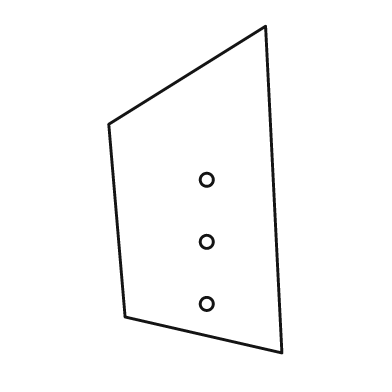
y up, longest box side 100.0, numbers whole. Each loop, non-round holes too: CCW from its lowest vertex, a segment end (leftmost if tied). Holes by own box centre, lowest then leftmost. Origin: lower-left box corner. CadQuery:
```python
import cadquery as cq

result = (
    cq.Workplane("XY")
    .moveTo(53.0, 0.0)
    .lineTo(48.0, 100.0)
    .lineTo(0.0, 70.0)
    .lineTo(5.0, 11.0)
    .close()
    .moveTo(30.0, 15.0)
    .circle(2.0)
    .moveTo(30.0, 34.0)
    .circle(2.0)
    .moveTo(30.0, 53.0)
    .circle(2.0)
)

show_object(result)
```